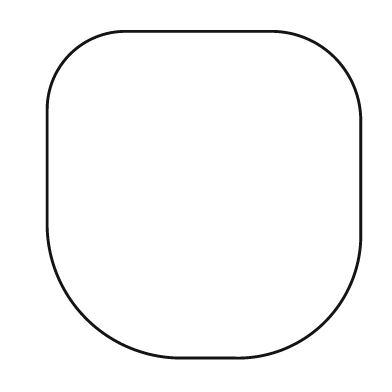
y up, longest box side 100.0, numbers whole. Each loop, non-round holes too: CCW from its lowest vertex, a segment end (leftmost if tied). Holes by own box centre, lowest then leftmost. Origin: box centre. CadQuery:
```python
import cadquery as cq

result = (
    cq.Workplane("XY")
    .moveTo(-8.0, -50.0)
    .lineTo(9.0, -50.0)
    .threePointArc((37.0, -39.0), (48.0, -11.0))
    .lineTo(48.0, 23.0)
    .threePointArc((40.0, 42.0), (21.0, 50.0))
    .lineTo(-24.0, 50.0)
    .threePointArc((-41.0, 43.0), (-48.0, 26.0))
    .lineTo(-48.0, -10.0)
    .threePointArc((-36.0, -38.0), (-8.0, -50.0))
    .close()
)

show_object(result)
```